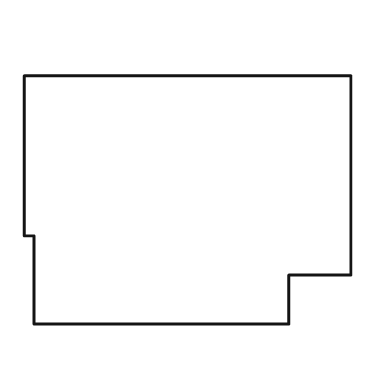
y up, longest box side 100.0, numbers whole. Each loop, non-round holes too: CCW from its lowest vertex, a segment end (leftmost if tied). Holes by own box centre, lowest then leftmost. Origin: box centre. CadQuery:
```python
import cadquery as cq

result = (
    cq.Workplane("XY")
    .moveTo(-47.0, -38.0)
    .lineTo(31.0, -38.0)
    .lineTo(31.0, -23.0)
    .lineTo(50.0, -23.0)
    .lineTo(50.0, 38.0)
    .lineTo(-50.0, 38.0)
    .lineTo(-50.0, -11.0)
    .lineTo(-47.0, -11.0)
    .close()
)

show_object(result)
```